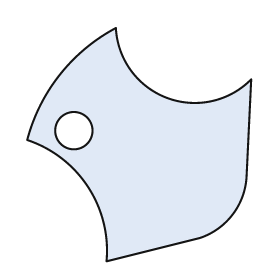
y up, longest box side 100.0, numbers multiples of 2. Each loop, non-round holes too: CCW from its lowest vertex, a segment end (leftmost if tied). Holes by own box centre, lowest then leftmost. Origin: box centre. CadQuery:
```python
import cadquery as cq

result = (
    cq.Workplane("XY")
    .moveTo(-14.0, -50.0)
    .lineTo(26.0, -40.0)
    .threePointArc((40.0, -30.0), (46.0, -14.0))
    .lineTo(48.0, 28.0)
    .threePointArc((12.0, 20.0), (-10.0, 50.0))
    .threePointArc((-34.0, 30.0), (-48.0, 2.0))
    .threePointArc((-22.0, -18.0), (-14.0, -50.0))
    .close()
    .moveTo(-28.0, 6.0)
    .circle(8.0)
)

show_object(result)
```